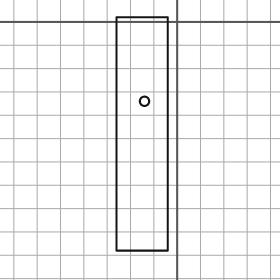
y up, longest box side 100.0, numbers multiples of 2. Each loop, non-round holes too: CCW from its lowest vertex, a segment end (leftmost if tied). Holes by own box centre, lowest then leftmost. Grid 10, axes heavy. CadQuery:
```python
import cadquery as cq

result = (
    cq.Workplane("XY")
    .moveTo(-26.0, -98.0)
    .lineTo(-4.0, -98.0)
    .lineTo(-4.0, 2.0)
    .lineTo(-26.0, 2.0)
    .close()
    .moveTo(-14.0, -34.0)
    .circle(2.0)
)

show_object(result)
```